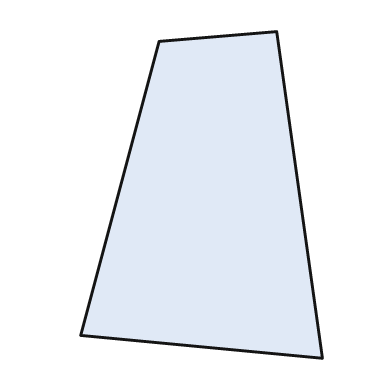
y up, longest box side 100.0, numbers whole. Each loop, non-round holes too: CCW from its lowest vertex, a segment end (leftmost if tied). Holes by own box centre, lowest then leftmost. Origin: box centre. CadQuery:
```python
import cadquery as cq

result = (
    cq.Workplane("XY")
    .moveTo(37.0, -50.0)
    .lineTo(23.0, 50.0)
    .lineTo(-13.0, 47.0)
    .lineTo(-37.0, -43.0)
    .close()
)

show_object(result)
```